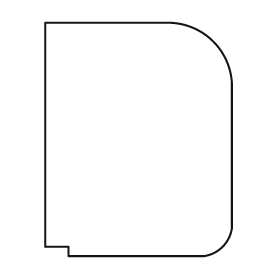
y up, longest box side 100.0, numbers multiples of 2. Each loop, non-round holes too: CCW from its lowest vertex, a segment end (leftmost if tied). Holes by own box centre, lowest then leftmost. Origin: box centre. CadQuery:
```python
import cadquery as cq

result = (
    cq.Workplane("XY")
    .moveTo(-30.0, -50.0)
    .lineTo(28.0, -50.0)
    .threePointArc((36.0, -46.0), (40.0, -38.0))
    .lineTo(40.0, 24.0)
    .threePointArc((32.0, 42.0), (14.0, 50.0))
    .lineTo(-40.0, 50.0)
    .lineTo(-40.0, -46.0)
    .lineTo(-30.0, -46.0)
    .close()
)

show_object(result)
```